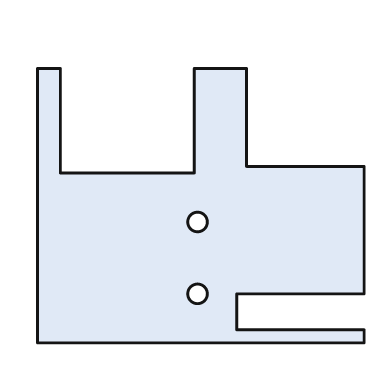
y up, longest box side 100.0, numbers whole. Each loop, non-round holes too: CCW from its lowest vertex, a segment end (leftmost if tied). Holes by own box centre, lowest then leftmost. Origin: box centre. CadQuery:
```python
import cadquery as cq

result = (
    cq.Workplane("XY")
    .moveTo(-50.0, -42.0)
    .lineTo(50.0, -42.0)
    .lineTo(50.0, -38.0)
    .lineTo(11.0, -38.0)
    .lineTo(11.0, -27.0)
    .lineTo(50.0, -27.0)
    .lineTo(50.0, 12.0)
    .lineTo(14.0, 12.0)
    .lineTo(14.0, 42.0)
    .lineTo(-2.0, 42.0)
    .lineTo(-2.0, 10.0)
    .lineTo(-43.0, 10.0)
    .lineTo(-43.0, 42.0)
    .lineTo(-50.0, 42.0)
    .close()
    .moveTo(-1.0, -27.0)
    .circle(3.0)
    .moveTo(-1.0, -5.0)
    .circle(3.0)
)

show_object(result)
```